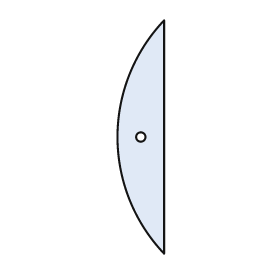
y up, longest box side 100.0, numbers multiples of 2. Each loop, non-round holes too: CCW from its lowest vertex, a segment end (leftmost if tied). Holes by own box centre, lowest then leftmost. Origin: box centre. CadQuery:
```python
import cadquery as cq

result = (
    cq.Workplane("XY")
    .moveTo(10.0, -50.0)
    .lineTo(10.0, 50.0)
    .threePointArc((-10.0, 0.0), (10.0, -50.0))
    .close()
    .moveTo(0.0, 0.0)
    .circle(2.0)
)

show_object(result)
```